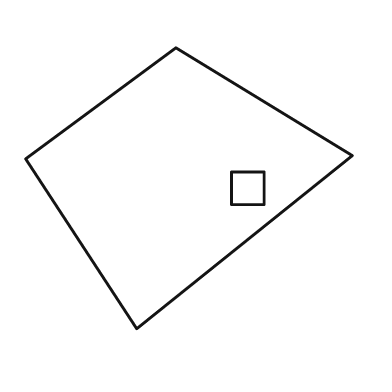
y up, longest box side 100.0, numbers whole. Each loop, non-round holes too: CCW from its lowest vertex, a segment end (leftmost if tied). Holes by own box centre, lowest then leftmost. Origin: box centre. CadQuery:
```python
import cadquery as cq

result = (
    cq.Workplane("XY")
    .moveTo(-16.0, -43.0)
    .lineTo(50.0, 10.0)
    .lineTo(-4.0, 43.0)
    .lineTo(-50.0, 9.0)
    .close()
    .moveTo(13.0, -5.0)
    .lineTo(23.0, -5.0)
    .lineTo(23.0, 5.0)
    .lineTo(13.0, 5.0)
    .close()
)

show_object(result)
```